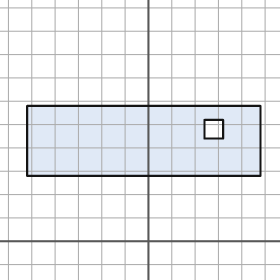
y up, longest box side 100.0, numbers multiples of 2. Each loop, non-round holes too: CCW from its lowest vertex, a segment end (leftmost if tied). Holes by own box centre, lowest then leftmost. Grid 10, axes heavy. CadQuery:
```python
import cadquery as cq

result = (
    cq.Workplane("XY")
    .moveTo(-52.0, 28.0)
    .lineTo(48.0, 28.0)
    .lineTo(48.0, 58.0)
    .lineTo(-52.0, 58.0)
    .close()
    .moveTo(24.0, 44.0)
    .lineTo(32.0, 44.0)
    .lineTo(32.0, 52.0)
    .lineTo(24.0, 52.0)
    .close()
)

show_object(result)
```